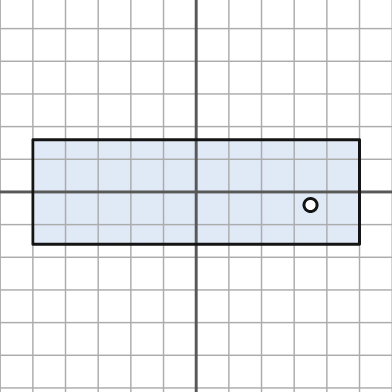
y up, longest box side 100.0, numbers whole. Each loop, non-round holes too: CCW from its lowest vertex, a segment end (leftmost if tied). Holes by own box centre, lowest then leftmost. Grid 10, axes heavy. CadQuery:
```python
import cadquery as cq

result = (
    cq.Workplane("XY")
    .moveTo(-50.0, -16.0)
    .lineTo(50.0, -16.0)
    .lineTo(50.0, 16.0)
    .lineTo(-50.0, 16.0)
    .close()
    .moveTo(35.0, -4.0)
    .circle(2.0)
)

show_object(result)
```